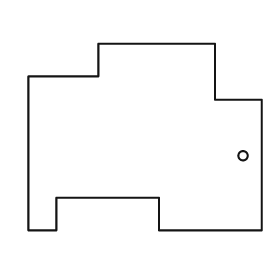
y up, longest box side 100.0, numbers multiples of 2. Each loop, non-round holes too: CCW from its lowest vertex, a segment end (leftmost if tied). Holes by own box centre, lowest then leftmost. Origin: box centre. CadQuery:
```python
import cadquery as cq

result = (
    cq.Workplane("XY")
    .moveTo(-50.0, -40.0)
    .lineTo(-38.0, -40.0)
    .lineTo(-38.0, -26.0)
    .lineTo(6.0, -26.0)
    .lineTo(6.0, -40.0)
    .lineTo(50.0, -40.0)
    .lineTo(50.0, 16.0)
    .lineTo(30.0, 16.0)
    .lineTo(30.0, 40.0)
    .lineTo(-20.0, 40.0)
    .lineTo(-20.0, 26.0)
    .lineTo(-50.0, 26.0)
    .close()
    .moveTo(42.0, -8.0)
    .circle(2.0)
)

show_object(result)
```